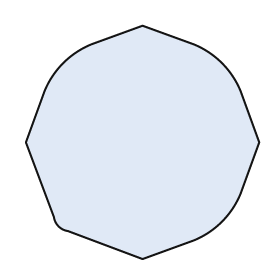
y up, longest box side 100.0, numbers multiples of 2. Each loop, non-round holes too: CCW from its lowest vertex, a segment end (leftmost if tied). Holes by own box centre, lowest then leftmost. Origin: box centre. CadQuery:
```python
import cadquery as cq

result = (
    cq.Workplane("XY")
    .moveTo(0.0, -50.0)
    .lineTo(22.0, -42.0)
    .threePointArc((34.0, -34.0), (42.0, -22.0))
    .lineTo(50.0, 0.0)
    .lineTo(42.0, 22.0)
    .threePointArc((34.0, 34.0), (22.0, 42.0))
    .lineTo(0.0, 50.0)
    .lineTo(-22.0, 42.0)
    .threePointArc((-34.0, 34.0), (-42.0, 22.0))
    .lineTo(-50.0, 0.0)
    .lineTo(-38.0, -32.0)
    .threePointArc((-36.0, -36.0), (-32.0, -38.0))
    .close()
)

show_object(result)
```